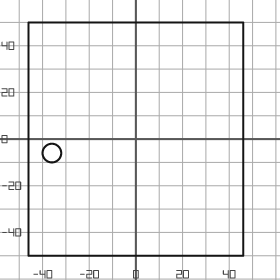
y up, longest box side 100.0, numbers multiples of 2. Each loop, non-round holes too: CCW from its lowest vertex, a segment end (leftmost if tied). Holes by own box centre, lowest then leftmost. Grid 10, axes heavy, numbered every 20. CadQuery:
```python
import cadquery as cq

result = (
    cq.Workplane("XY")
    .moveTo(-46.0, -50.0)
    .lineTo(46.0, -50.0)
    .lineTo(46.0, 50.0)
    .lineTo(-46.0, 50.0)
    .close()
    .moveTo(-36.0, -6.0)
    .circle(4.0)
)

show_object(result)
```